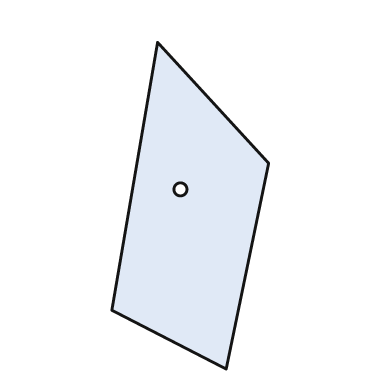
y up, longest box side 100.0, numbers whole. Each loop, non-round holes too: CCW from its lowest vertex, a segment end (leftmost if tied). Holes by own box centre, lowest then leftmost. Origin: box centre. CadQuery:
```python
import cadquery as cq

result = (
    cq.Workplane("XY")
    .moveTo(11.0, -50.0)
    .lineTo(24.0, 13.0)
    .lineTo(-10.0, 50.0)
    .lineTo(-24.0, -32.0)
    .close()
    .moveTo(-3.0, 5.0)
    .circle(2.0)
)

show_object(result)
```